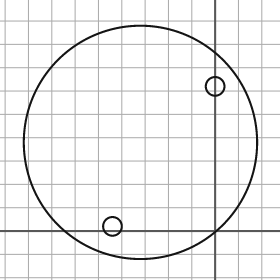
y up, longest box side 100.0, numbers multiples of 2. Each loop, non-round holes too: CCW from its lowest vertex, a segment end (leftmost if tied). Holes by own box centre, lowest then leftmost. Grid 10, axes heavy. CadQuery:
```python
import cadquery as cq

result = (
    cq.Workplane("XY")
    .moveTo(-32.0, 38.0)
    .circle(50.0)
    .moveTo(-44.0, 2.0)
    .circle(4.0)
    .moveTo(0.0, 62.0)
    .circle(4.0)
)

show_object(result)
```